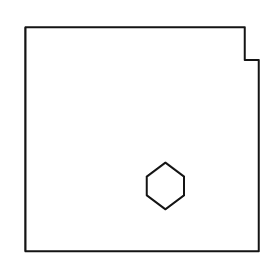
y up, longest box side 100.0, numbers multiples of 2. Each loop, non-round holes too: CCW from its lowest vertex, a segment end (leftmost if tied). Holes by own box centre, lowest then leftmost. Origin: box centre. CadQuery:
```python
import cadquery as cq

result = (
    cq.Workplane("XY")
    .moveTo(-50.0, -48.0)
    .lineTo(50.0, -48.0)
    .lineTo(50.0, 34.0)
    .lineTo(44.0, 34.0)
    .lineTo(44.0, 48.0)
    .lineTo(-50.0, 48.0)
    .close()
    .moveTo(10.0, -30.0)
    .lineTo(18.0, -24.0)
    .lineTo(18.0, -16.0)
    .lineTo(10.0, -10.0)
    .lineTo(2.0, -16.0)
    .lineTo(2.0, -24.0)
    .close()
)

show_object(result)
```